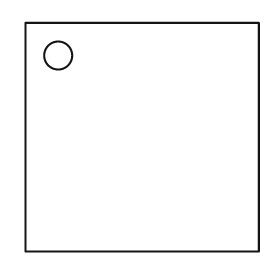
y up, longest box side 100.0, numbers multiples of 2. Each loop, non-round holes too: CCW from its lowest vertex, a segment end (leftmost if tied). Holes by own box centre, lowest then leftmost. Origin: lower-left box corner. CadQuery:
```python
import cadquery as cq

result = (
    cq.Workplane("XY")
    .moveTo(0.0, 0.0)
    .lineTo(100.0, 0.0)
    .lineTo(100.0, 98.0)
    .lineTo(0.0, 98.0)
    .close()
    .moveTo(14.0, 84.0)
    .circle(6.0)
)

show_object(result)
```